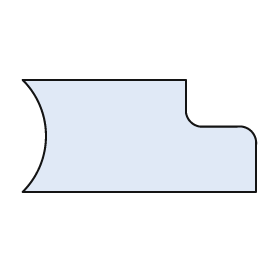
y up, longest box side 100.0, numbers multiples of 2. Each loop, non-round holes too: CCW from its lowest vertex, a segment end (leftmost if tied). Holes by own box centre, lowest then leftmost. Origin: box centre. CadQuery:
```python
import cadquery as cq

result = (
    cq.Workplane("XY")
    .moveTo(-50.0, -24.0)
    .lineTo(50.0, -24.0)
    .lineTo(50.0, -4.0)
    .threePointArc((48.0, 2.0), (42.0, 4.0))
    .lineTo(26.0, 4.0)
    .threePointArc((22.0, 6.0), (20.0, 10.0))
    .lineTo(20.0, 24.0)
    .lineTo(-50.0, 24.0)
    .threePointArc((-40.0, 0.0), (-50.0, -24.0))
    .close()
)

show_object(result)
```